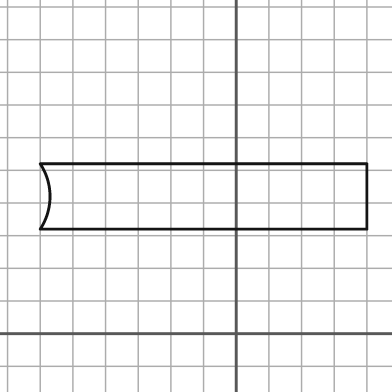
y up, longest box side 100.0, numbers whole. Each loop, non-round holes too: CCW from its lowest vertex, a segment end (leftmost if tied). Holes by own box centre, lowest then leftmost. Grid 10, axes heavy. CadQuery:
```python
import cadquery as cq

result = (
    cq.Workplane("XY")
    .moveTo(-60.0, 32.0)
    .lineTo(40.0, 32.0)
    .lineTo(40.0, 52.0)
    .lineTo(-60.0, 52.0)
    .threePointArc((-57.0, 42.0), (-60.0, 32.0))
    .close()
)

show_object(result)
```